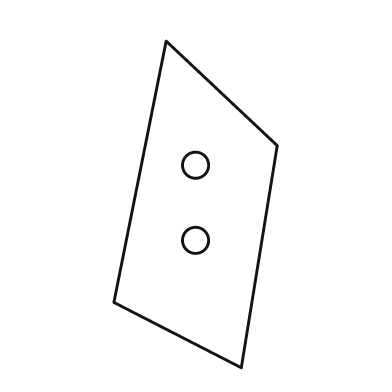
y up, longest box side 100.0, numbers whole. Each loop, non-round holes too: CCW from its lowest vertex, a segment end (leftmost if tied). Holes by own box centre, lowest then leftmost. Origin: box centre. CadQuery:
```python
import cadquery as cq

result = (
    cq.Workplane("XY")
    .moveTo(14.0, -50.0)
    .lineTo(25.0, 18.0)
    .lineTo(-9.0, 50.0)
    .lineTo(-25.0, -30.0)
    .close()
    .moveTo(0.0, -11.0)
    .circle(4.0)
    .moveTo(0.0, 12.0)
    .circle(4.0)
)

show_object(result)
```